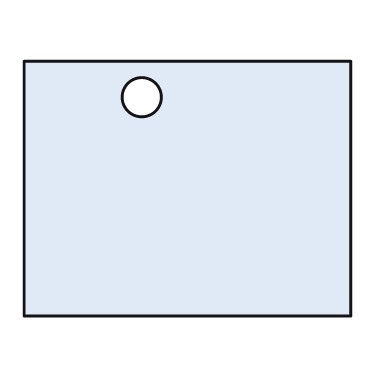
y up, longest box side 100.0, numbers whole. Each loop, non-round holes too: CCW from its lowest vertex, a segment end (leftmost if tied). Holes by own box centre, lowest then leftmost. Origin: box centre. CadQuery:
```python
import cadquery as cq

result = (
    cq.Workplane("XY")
    .moveTo(-50.0, -39.0)
    .lineTo(50.0, -39.0)
    .lineTo(50.0, 39.0)
    .lineTo(-50.0, 39.0)
    .close()
    .moveTo(-14.0, 28.0)
    .circle(6.0)
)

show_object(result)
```